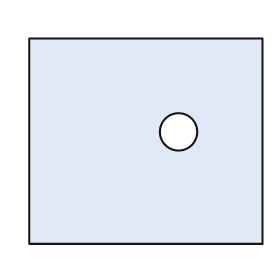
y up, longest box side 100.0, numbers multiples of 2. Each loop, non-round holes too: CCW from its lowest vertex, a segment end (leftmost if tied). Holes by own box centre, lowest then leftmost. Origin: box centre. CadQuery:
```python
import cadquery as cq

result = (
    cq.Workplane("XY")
    .moveTo(-50.0, -44.0)
    .lineTo(50.0, -44.0)
    .lineTo(50.0, 44.0)
    .lineTo(-50.0, 44.0)
    .close()
    .moveTo(14.0, 4.0)
    .circle(8.0)
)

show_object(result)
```